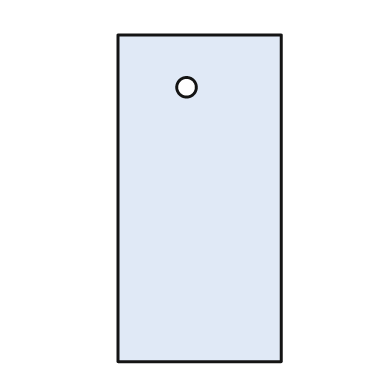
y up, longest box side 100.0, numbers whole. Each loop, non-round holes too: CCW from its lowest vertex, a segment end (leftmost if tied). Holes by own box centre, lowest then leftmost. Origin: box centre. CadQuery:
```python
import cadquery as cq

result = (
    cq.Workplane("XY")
    .moveTo(-25.0, -50.0)
    .lineTo(25.0, -50.0)
    .lineTo(25.0, 50.0)
    .lineTo(-25.0, 50.0)
    .close()
    .moveTo(-4.0, 34.0)
    .circle(3.0)
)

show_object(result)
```